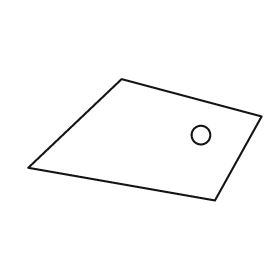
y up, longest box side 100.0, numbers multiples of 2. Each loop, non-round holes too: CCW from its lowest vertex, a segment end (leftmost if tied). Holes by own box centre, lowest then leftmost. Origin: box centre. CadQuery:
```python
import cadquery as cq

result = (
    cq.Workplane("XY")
    .moveTo(30.0, -26.0)
    .lineTo(50.0, 10.0)
    .lineTo(-10.0, 26.0)
    .lineTo(-50.0, -12.0)
    .close()
    .moveTo(24.0, 2.0)
    .circle(4.0)
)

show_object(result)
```